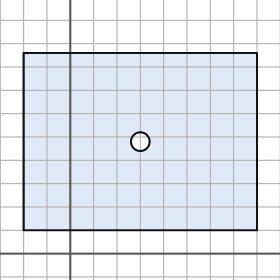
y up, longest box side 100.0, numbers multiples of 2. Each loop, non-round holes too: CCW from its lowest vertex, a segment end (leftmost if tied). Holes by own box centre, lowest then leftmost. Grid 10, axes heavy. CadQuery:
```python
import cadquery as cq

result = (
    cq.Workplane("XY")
    .moveTo(-20.0, 10.0)
    .lineTo(80.0, 10.0)
    .lineTo(80.0, 86.0)
    .lineTo(-20.0, 86.0)
    .close()
    .moveTo(30.0, 48.0)
    .circle(4.0)
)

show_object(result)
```